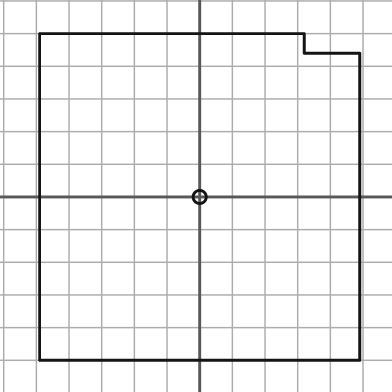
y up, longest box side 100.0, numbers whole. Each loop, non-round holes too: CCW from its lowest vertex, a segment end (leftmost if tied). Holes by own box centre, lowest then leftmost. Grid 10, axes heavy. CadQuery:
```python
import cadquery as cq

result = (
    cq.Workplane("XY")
    .moveTo(-49.0, -50.0)
    .lineTo(49.0, -50.0)
    .lineTo(49.0, 44.0)
    .lineTo(32.0, 44.0)
    .lineTo(32.0, 50.0)
    .lineTo(-49.0, 50.0)
    .close()
    .moveTo(0.0, 0.0)
    .circle(2.0)
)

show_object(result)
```